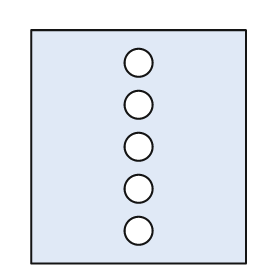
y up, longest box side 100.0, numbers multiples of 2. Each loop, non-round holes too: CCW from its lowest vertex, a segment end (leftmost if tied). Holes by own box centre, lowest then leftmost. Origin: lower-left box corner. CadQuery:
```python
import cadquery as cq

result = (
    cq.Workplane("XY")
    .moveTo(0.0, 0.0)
    .lineTo(92.0, 0.0)
    .lineTo(92.0, 100.0)
    .lineTo(0.0, 100.0)
    .close()
    .moveTo(46.0, 14.0)
    .circle(6.0)
    .moveTo(46.0, 32.0)
    .circle(6.0)
    .moveTo(46.0, 50.0)
    .circle(6.0)
    .moveTo(46.0, 68.0)
    .circle(6.0)
    .moveTo(46.0, 86.0)
    .circle(6.0)
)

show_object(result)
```